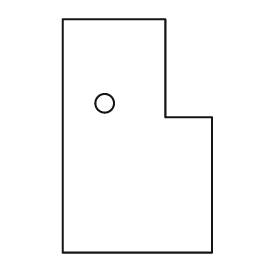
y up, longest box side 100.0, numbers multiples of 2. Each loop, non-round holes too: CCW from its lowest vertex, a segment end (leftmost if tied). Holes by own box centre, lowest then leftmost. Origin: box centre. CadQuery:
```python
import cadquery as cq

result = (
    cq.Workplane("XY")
    .moveTo(-32.0, -50.0)
    .lineTo(32.0, -50.0)
    .lineTo(32.0, 8.0)
    .lineTo(12.0, 8.0)
    .lineTo(12.0, 50.0)
    .lineTo(-32.0, 50.0)
    .close()
    .moveTo(-14.0, 14.0)
    .circle(4.0)
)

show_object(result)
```